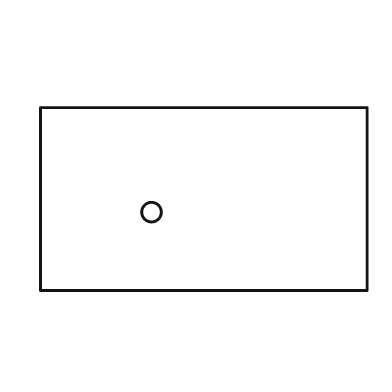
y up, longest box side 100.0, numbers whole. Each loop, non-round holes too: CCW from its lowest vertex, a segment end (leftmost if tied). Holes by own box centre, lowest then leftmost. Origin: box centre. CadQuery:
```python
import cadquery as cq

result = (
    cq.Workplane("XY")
    .moveTo(-50.0, -28.0)
    .lineTo(50.0, -28.0)
    .lineTo(50.0, 28.0)
    .lineTo(-50.0, 28.0)
    .close()
    .moveTo(-16.0, -4.0)
    .circle(3.0)
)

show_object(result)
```